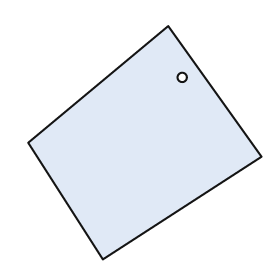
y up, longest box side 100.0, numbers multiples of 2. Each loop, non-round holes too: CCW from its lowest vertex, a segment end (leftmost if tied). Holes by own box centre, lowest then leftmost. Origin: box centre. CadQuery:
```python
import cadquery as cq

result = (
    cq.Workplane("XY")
    .moveTo(-18.0, -50.0)
    .lineTo(50.0, -6.0)
    .lineTo(10.0, 50.0)
    .lineTo(-50.0, 0.0)
    .close()
    .moveTo(16.0, 28.0)
    .circle(2.0)
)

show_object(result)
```